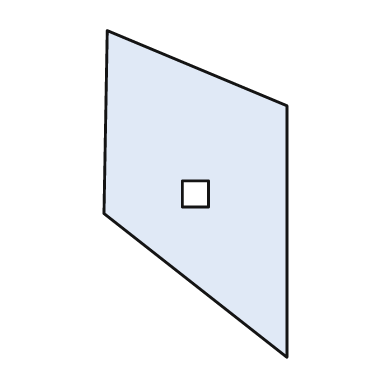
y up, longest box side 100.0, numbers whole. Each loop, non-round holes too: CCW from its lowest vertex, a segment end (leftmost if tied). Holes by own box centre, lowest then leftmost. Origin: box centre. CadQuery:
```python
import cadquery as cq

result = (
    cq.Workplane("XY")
    .moveTo(28.0, -50.0)
    .lineTo(28.0, 27.0)
    .lineTo(-27.0, 50.0)
    .lineTo(-28.0, -6.0)
    .close()
    .moveTo(-4.0, -4.0)
    .lineTo(4.0, -4.0)
    .lineTo(4.0, 4.0)
    .lineTo(-4.0, 4.0)
    .close()
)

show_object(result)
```